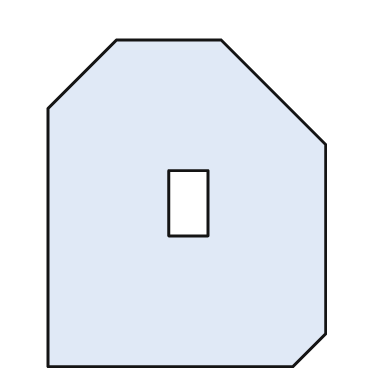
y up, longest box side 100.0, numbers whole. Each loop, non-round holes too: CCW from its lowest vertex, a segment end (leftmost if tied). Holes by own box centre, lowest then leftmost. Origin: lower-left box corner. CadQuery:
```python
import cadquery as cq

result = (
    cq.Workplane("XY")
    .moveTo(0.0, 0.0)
    .lineTo(75.0, 0.0)
    .lineTo(85.0, 10.0)
    .lineTo(85.0, 68.0)
    .lineTo(53.0, 100.0)
    .lineTo(21.0, 100.0)
    .lineTo(0.0, 79.0)
    .close()
    .moveTo(37.0, 40.0)
    .lineTo(49.0, 40.0)
    .lineTo(49.0, 60.0)
    .lineTo(37.0, 60.0)
    .close()
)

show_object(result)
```